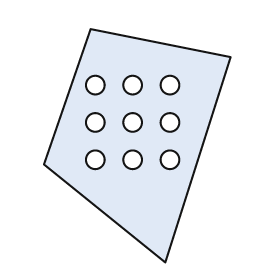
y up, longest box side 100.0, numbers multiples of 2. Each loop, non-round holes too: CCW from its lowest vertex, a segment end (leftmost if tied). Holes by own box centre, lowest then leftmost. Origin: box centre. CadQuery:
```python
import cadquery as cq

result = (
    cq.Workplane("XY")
    .moveTo(12.0, -50.0)
    .lineTo(40.0, 38.0)
    .lineTo(-20.0, 50.0)
    .lineTo(-40.0, -8.0)
    .close()
    .moveTo(-18.0, -6.0)
    .circle(4.0)
    .moveTo(-2.0, -6.0)
    .circle(4.0)
    .moveTo(14.0, -6.0)
    .circle(4.0)
    .moveTo(-18.0, 10.0)
    .circle(4.0)
    .moveTo(-2.0, 10.0)
    .circle(4.0)
    .moveTo(14.0, 10.0)
    .circle(4.0)
    .moveTo(-18.0, 26.0)
    .circle(4.0)
    .moveTo(-2.0, 26.0)
    .circle(4.0)
    .moveTo(14.0, 26.0)
    .circle(4.0)
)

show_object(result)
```